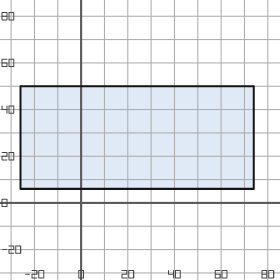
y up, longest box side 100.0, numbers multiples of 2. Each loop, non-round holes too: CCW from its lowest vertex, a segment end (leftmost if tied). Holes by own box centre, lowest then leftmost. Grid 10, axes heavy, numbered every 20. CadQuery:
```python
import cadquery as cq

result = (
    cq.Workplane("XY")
    .moveTo(-26.0, 6.0)
    .lineTo(74.0, 6.0)
    .lineTo(74.0, 50.0)
    .lineTo(-26.0, 50.0)
    .close()
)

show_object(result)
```